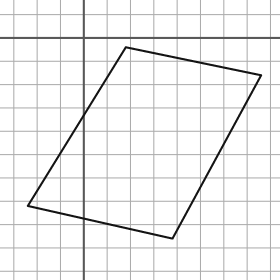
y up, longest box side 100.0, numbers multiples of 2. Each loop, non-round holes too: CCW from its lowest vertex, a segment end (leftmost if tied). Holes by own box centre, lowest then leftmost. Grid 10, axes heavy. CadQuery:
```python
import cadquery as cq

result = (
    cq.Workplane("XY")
    .moveTo(38.0, -86.0)
    .lineTo(76.0, -16.0)
    .lineTo(18.0, -4.0)
    .lineTo(-24.0, -72.0)
    .close()
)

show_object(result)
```